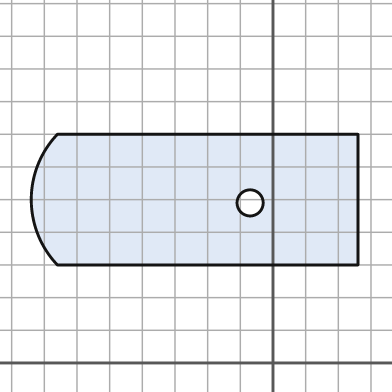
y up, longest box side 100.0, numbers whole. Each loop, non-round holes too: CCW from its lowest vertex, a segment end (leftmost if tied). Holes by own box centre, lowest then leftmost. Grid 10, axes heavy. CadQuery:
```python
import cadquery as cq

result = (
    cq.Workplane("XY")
    .moveTo(-66.0, 30.0)
    .lineTo(26.0, 30.0)
    .lineTo(26.0, 70.0)
    .lineTo(-66.0, 70.0)
    .threePointArc((-74.0, 50.0), (-66.0, 30.0))
    .close()
    .moveTo(-7.0, 49.0)
    .circle(4.0)
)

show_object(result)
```